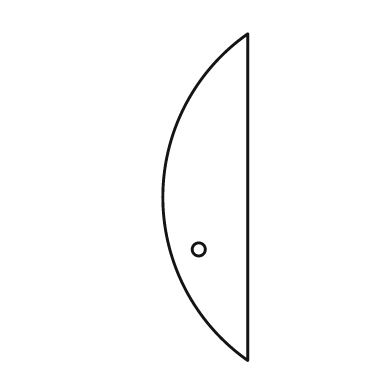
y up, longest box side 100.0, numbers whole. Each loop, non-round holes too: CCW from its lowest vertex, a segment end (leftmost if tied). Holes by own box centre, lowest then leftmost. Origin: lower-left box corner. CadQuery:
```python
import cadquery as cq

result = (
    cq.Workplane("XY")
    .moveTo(26.0, 0.0)
    .lineTo(26.0, 100.0)
    .threePointArc((0.0, 50.0), (26.0, 0.0))
    .close()
    .moveTo(11.0, 34.0)
    .circle(2.0)
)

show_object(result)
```